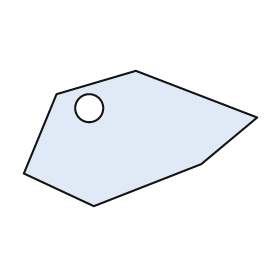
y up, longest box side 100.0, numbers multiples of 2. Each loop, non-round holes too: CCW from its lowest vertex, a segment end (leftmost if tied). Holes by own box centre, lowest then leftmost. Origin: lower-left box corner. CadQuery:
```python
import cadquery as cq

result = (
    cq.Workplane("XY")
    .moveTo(30.0, 0.0)
    .lineTo(76.0, 18.0)
    .lineTo(100.0, 38.0)
    .lineTo(48.0, 58.0)
    .lineTo(14.0, 48.0)
    .lineTo(0.0, 14.0)
    .close()
    .moveTo(28.0, 42.0)
    .circle(6.0)
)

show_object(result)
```